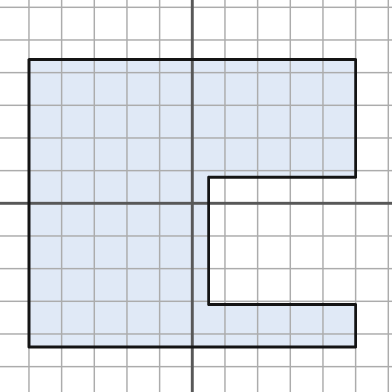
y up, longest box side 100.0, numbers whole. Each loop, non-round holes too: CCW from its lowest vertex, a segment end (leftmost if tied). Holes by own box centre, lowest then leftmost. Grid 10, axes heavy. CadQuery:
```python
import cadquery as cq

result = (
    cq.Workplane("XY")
    .moveTo(-50.0, -44.0)
    .lineTo(50.0, -44.0)
    .lineTo(50.0, -31.0)
    .lineTo(5.0, -31.0)
    .lineTo(5.0, 8.0)
    .lineTo(50.0, 8.0)
    .lineTo(50.0, 44.0)
    .lineTo(-50.0, 44.0)
    .close()
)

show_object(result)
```